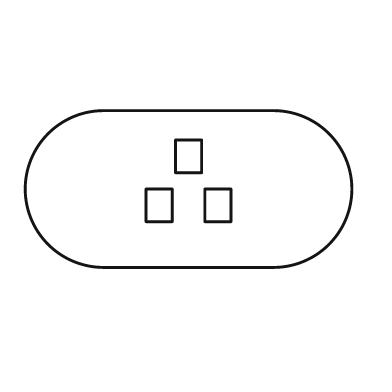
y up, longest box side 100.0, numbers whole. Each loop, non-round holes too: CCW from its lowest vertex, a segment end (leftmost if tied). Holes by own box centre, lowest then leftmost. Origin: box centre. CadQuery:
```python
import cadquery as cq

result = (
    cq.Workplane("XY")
    .moveTo(-26.0, -24.0)
    .lineTo(26.0, -24.0)
    .threePointArc((50.0, 0.0), (26.0, 24.0))
    .lineTo(-26.0, 24.0)
    .threePointArc((-50.0, 0.0), (-26.0, -24.0))
    .close()
    .moveTo(-13.0, -10.0)
    .lineTo(-5.0, -10.0)
    .lineTo(-5.0, 0.0)
    .lineTo(-13.0, 0.0)
    .close()
    .moveTo(5.0, -10.0)
    .lineTo(13.0, -10.0)
    .lineTo(13.0, 0.0)
    .lineTo(5.0, 0.0)
    .close()
    .moveTo(-4.0, 5.0)
    .lineTo(4.0, 5.0)
    .lineTo(4.0, 15.0)
    .lineTo(-4.0, 15.0)
    .close()
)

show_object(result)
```